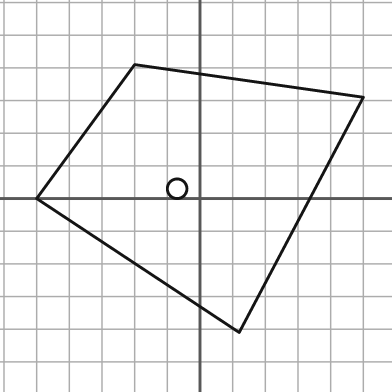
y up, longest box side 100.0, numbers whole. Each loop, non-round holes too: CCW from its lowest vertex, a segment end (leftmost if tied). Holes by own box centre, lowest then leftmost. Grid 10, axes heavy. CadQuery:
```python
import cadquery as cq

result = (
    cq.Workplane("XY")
    .moveTo(12.0, -41.0)
    .lineTo(50.0, 31.0)
    .lineTo(-20.0, 41.0)
    .lineTo(-50.0, 0.0)
    .close()
    .moveTo(-7.0, 3.0)
    .circle(3.0)
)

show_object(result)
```